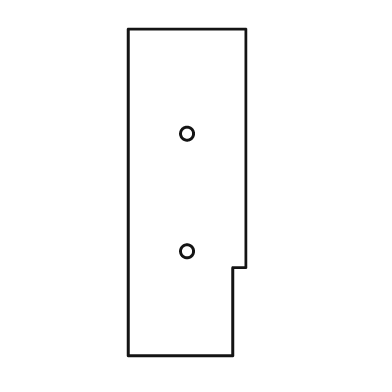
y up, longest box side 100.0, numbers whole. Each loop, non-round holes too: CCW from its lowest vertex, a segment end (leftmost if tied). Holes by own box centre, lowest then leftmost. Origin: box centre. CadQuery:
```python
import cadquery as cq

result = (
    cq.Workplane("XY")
    .moveTo(-18.0, -50.0)
    .lineTo(14.0, -50.0)
    .lineTo(14.0, -23.0)
    .lineTo(18.0, -23.0)
    .lineTo(18.0, 50.0)
    .lineTo(-18.0, 50.0)
    .close()
    .moveTo(0.0, -18.0)
    .circle(2.0)
    .moveTo(0.0, 18.0)
    .circle(2.0)
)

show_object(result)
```